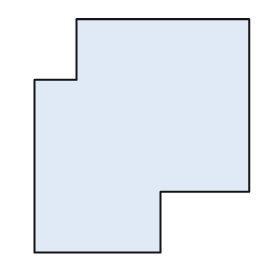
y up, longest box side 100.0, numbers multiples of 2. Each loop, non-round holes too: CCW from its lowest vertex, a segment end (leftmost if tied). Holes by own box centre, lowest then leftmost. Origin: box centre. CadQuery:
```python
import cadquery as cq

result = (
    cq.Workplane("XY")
    .moveTo(-46.0, -50.0)
    .lineTo(8.0, -50.0)
    .lineTo(8.0, -24.0)
    .lineTo(46.0, -24.0)
    .lineTo(46.0, 50.0)
    .lineTo(-28.0, 50.0)
    .lineTo(-28.0, 24.0)
    .lineTo(-46.0, 24.0)
    .close()
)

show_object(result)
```